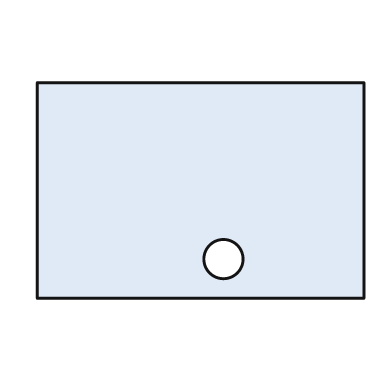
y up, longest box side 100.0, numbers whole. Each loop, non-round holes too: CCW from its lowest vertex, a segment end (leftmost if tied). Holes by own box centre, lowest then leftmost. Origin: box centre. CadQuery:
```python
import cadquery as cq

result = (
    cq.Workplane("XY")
    .moveTo(-50.0, -33.0)
    .lineTo(50.0, -33.0)
    .lineTo(50.0, 33.0)
    .lineTo(-50.0, 33.0)
    .close()
    .moveTo(7.0, -21.0)
    .circle(6.0)
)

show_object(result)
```